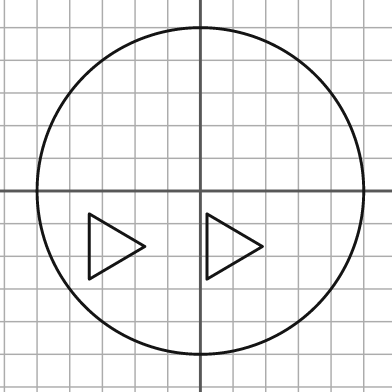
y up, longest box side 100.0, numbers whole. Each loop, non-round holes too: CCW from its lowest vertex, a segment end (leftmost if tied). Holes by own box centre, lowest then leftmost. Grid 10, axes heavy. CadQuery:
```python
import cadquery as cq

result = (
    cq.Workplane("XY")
    .moveTo(0.0, 0.0)
    .circle(50.0)
    .moveTo(-34.0, -27.0)
    .lineTo(-17.0, -17.0)
    .lineTo(-34.0, -7.0)
    .close()
    .moveTo(2.0, -27.0)
    .lineTo(19.0, -17.0)
    .lineTo(2.0, -7.0)
    .close()
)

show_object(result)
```